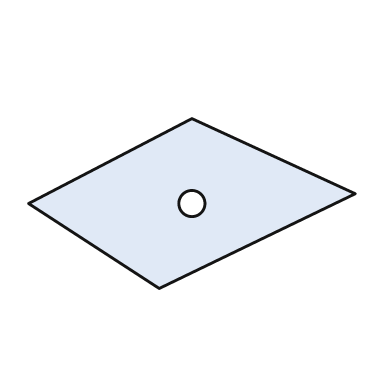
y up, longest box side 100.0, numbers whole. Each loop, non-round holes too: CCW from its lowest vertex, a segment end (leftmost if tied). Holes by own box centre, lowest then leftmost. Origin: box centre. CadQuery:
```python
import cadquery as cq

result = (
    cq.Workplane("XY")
    .moveTo(-10.0, -26.0)
    .lineTo(50.0, 3.0)
    .lineTo(0.0, 26.0)
    .lineTo(-50.0, 0.0)
    .close()
    .moveTo(0.0, 0.0)
    .circle(4.0)
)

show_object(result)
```